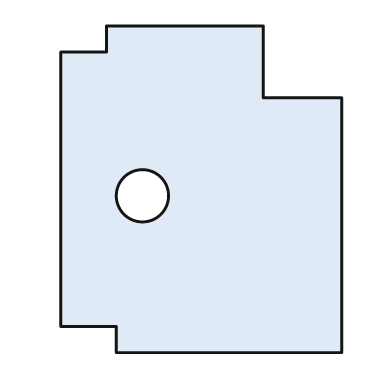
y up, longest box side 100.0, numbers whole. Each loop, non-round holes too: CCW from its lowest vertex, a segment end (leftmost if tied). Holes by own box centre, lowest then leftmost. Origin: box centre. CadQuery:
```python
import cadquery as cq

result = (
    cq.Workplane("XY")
    .moveTo(-26.0, -50.0)
    .lineTo(43.0, -50.0)
    .lineTo(43.0, 28.0)
    .lineTo(19.0, 28.0)
    .lineTo(19.0, 50.0)
    .lineTo(-29.0, 50.0)
    .lineTo(-29.0, 42.0)
    .lineTo(-43.0, 42.0)
    .lineTo(-43.0, -42.0)
    .lineTo(-26.0, -42.0)
    .close()
    .moveTo(-18.0, -2.0)
    .circle(8.0)
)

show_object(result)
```